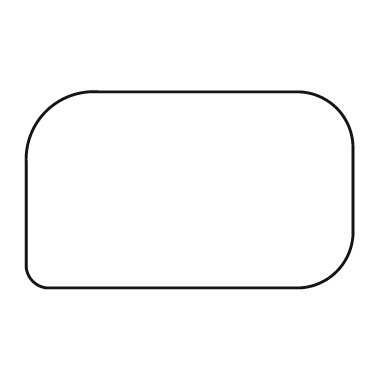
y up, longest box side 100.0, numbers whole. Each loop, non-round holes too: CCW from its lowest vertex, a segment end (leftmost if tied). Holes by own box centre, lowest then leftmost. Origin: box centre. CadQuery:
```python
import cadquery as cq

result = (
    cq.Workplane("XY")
    .moveTo(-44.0, -30.0)
    .lineTo(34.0, -30.0)
    .threePointArc((45.0, -25.0), (50.0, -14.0))
    .lineTo(50.0, 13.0)
    .threePointArc((45.0, 25.0), (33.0, 30.0))
    .lineTo(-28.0, 30.0)
    .threePointArc((-44.0, 24.0), (-50.0, 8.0))
    .lineTo(-50.0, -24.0)
    .threePointArc((-48.0, -28.0), (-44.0, -30.0))
    .close()
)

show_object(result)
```